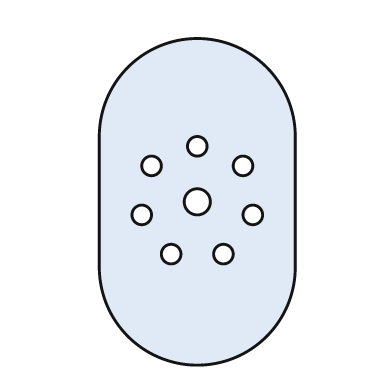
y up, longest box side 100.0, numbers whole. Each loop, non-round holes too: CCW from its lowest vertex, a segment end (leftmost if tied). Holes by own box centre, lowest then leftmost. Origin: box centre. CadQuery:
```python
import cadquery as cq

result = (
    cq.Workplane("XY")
    .moveTo(-30.0, -20.0)
    .threePointArc((0.0, -50.0), (30.0, -20.0))
    .lineTo(30.0, 20.0)
    .threePointArc((0.0, 50.0), (-30.0, 20.0))
    .close()
    .moveTo(-8.0, -16.0)
    .circle(3.0)
    .moveTo(8.0, -16.0)
    .circle(3.0)
    .moveTo(-17.0, -4.0)
    .circle(3.0)
    .moveTo(17.0, -4.0)
    .circle(3.0)
    .moveTo(0.0, 0.0)
    .circle(4.0)
    .moveTo(-14.0, 11.0)
    .circle(3.0)
    .moveTo(14.0, 11.0)
    .circle(3.0)
    .moveTo(0.0, 17.0)
    .circle(3.0)
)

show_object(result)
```